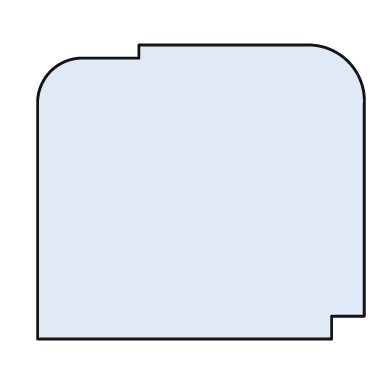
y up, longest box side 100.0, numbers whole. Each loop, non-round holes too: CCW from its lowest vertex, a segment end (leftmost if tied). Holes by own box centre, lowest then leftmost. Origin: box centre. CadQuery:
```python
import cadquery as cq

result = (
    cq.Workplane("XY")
    .moveTo(-50.0, -45.0)
    .lineTo(40.0, -45.0)
    .lineTo(40.0, -38.0)
    .lineTo(50.0, -38.0)
    .lineTo(50.0, 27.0)
    .threePointArc((45.0, 40.0), (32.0, 45.0))
    .lineTo(-19.0, 45.0)
    .lineTo(-19.0, 41.0)
    .lineTo(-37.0, 41.0)
    .threePointArc((-46.0, 37.0), (-50.0, 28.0))
    .close()
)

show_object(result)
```